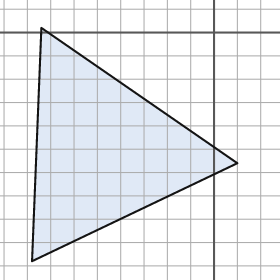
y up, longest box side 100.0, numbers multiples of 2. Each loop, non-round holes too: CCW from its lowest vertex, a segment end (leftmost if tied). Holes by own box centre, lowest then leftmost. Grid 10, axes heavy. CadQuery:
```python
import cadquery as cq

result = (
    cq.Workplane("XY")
    .moveTo(-78.0, -98.0)
    .lineTo(10.0, -56.0)
    .lineTo(-74.0, 2.0)
    .close()
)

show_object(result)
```